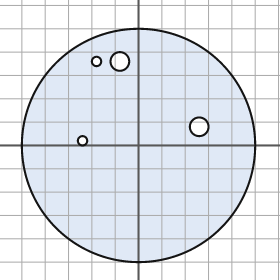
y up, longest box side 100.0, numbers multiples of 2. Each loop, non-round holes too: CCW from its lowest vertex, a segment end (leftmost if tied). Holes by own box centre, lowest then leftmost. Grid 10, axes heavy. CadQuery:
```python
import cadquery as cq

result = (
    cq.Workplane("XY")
    .moveTo(0.0, 0.0)
    .circle(50.0)
    .moveTo(-24.0, 2.0)
    .circle(2.0)
    .moveTo(26.0, 8.0)
    .circle(4.0)
    .moveTo(-18.0, 36.0)
    .circle(2.0)
    .moveTo(-8.0, 36.0)
    .circle(4.0)
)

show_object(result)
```